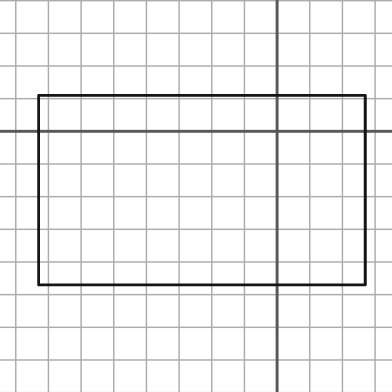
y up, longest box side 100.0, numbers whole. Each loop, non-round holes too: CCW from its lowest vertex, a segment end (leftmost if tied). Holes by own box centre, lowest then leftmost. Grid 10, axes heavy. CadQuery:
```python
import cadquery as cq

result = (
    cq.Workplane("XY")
    .moveTo(-73.0, -47.0)
    .lineTo(27.0, -47.0)
    .lineTo(27.0, 11.0)
    .lineTo(-73.0, 11.0)
    .close()
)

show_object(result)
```